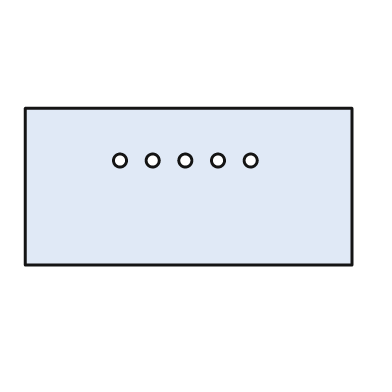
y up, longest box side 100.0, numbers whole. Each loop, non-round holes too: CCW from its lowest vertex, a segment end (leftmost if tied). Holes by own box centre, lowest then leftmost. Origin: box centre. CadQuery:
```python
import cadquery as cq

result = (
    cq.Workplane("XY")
    .moveTo(-50.0, -24.0)
    .lineTo(50.0, -24.0)
    .lineTo(50.0, 24.0)
    .lineTo(-50.0, 24.0)
    .close()
    .moveTo(-21.0, 8.0)
    .circle(2.0)
    .moveTo(-11.0, 8.0)
    .circle(2.0)
    .moveTo(-1.0, 8.0)
    .circle(2.0)
    .moveTo(9.0, 8.0)
    .circle(2.0)
    .moveTo(19.0, 8.0)
    .circle(2.0)
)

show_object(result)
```